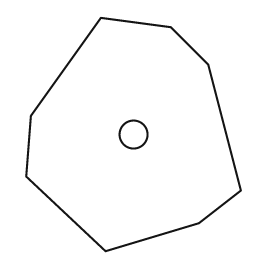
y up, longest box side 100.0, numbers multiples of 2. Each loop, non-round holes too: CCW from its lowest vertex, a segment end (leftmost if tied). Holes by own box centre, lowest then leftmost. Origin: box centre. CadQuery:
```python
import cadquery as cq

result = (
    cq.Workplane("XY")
    .moveTo(-12.0, -50.0)
    .lineTo(28.0, -38.0)
    .lineTo(46.0, -24.0)
    .lineTo(32.0, 30.0)
    .lineTo(16.0, 46.0)
    .lineTo(-14.0, 50.0)
    .lineTo(-44.0, 8.0)
    .lineTo(-46.0, -18.0)
    .close()
    .moveTo(0.0, 0.0)
    .circle(6.0)
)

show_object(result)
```